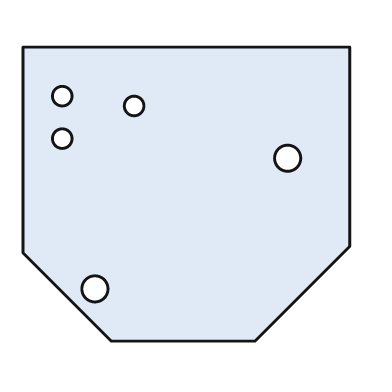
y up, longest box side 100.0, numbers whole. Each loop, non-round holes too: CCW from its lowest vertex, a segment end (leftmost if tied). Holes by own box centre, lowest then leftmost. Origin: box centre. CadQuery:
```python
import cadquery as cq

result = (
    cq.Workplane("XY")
    .moveTo(-23.0, -45.0)
    .lineTo(21.0, -45.0)
    .lineTo(50.0, -16.0)
    .lineTo(50.0, 45.0)
    .lineTo(-50.0, 45.0)
    .lineTo(-50.0, -18.0)
    .close()
    .moveTo(-28.0, -29.0)
    .circle(4.0)
    .moveTo(31.0, 11.0)
    .circle(4.0)
    .moveTo(-38.0, 17.0)
    .circle(3.0)
    .moveTo(-16.0, 27.0)
    .circle(3.0)
    .moveTo(-38.0, 30.0)
    .circle(3.0)
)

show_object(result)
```